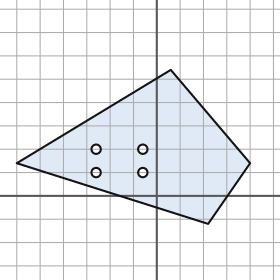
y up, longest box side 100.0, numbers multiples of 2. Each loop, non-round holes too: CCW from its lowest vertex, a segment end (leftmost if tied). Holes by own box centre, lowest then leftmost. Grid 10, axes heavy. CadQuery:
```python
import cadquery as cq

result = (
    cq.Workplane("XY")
    .moveTo(22.0, -12.0)
    .lineTo(40.0, 14.0)
    .lineTo(6.0, 54.0)
    .lineTo(-60.0, 14.0)
    .close()
    .moveTo(-26.0, 10.0)
    .circle(2.0)
    .moveTo(-6.0, 10.0)
    .circle(2.0)
    .moveTo(-26.0, 20.0)
    .circle(2.0)
    .moveTo(-6.0, 20.0)
    .circle(2.0)
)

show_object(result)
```